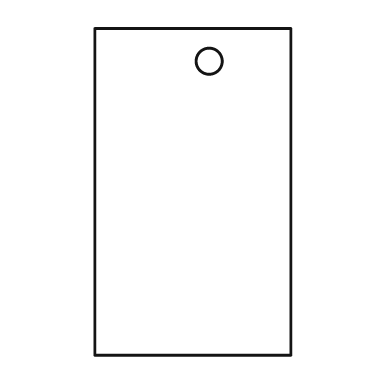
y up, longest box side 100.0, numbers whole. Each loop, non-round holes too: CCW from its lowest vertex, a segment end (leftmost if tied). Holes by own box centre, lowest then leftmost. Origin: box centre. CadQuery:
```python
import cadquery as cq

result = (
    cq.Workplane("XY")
    .moveTo(-30.0, -50.0)
    .lineTo(30.0, -50.0)
    .lineTo(30.0, 50.0)
    .lineTo(-30.0, 50.0)
    .close()
    .moveTo(5.0, 40.0)
    .circle(4.0)
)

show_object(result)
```